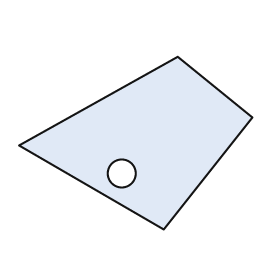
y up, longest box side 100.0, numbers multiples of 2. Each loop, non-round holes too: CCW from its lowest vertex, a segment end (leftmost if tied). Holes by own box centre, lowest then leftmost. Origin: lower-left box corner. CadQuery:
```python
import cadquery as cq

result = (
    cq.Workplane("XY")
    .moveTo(62.0, 0.0)
    .lineTo(100.0, 48.0)
    .lineTo(68.0, 74.0)
    .lineTo(0.0, 36.0)
    .close()
    .moveTo(44.0, 24.0)
    .circle(6.0)
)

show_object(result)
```